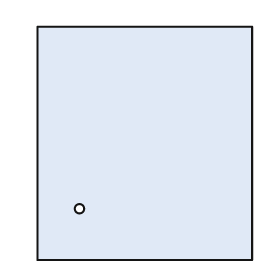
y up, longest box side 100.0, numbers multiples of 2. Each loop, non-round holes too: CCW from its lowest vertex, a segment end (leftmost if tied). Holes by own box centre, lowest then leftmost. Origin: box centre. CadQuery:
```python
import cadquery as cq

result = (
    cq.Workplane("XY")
    .moveTo(-46.0, -50.0)
    .lineTo(46.0, -50.0)
    .lineTo(46.0, 50.0)
    .lineTo(-46.0, 50.0)
    .close()
    .moveTo(-28.0, -28.0)
    .circle(2.0)
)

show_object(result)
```